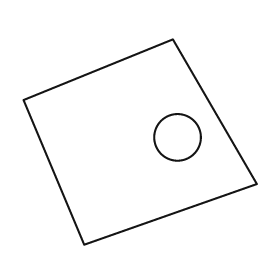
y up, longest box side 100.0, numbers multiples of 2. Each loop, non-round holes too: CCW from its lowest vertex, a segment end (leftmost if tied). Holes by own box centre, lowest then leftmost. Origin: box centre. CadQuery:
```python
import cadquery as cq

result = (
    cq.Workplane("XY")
    .moveTo(-24.0, -44.0)
    .lineTo(50.0, -18.0)
    .lineTo(14.0, 44.0)
    .lineTo(-50.0, 18.0)
    .close()
    .moveTo(16.0, 2.0)
    .circle(10.0)
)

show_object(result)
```